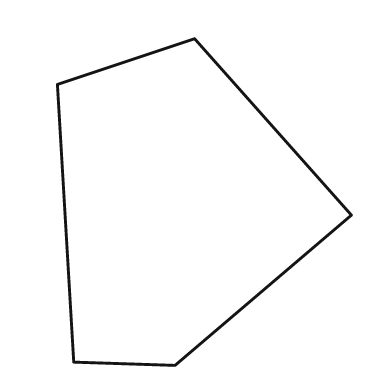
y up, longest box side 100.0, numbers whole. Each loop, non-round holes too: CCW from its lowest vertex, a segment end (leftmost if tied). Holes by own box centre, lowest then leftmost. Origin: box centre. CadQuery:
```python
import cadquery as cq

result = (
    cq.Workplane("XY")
    .moveTo(-9.0, -50.0)
    .lineTo(45.0, -4.0)
    .lineTo(-3.0, 50.0)
    .lineTo(-45.0, 36.0)
    .lineTo(-40.0, -49.0)
    .close()
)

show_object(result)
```